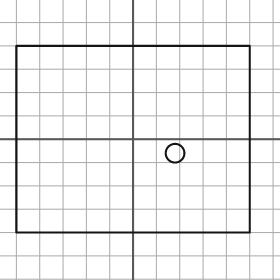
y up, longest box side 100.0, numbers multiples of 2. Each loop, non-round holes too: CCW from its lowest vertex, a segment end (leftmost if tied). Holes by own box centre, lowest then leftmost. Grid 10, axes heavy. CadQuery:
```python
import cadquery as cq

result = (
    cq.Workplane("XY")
    .moveTo(-50.0, -40.0)
    .lineTo(50.0, -40.0)
    .lineTo(50.0, 40.0)
    .lineTo(-50.0, 40.0)
    .close()
    .moveTo(18.0, -6.0)
    .circle(4.0)
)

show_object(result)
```